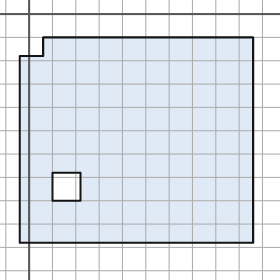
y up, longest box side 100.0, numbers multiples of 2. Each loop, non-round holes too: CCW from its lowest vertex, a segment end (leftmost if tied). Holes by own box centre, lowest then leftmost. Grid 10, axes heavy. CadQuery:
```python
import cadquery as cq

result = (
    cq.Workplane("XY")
    .moveTo(-4.0, -98.0)
    .lineTo(96.0, -98.0)
    .lineTo(96.0, -10.0)
    .lineTo(6.0, -10.0)
    .lineTo(6.0, -18.0)
    .lineTo(-4.0, -18.0)
    .close()
    .moveTo(10.0, -80.0)
    .lineTo(22.0, -80.0)
    .lineTo(22.0, -68.0)
    .lineTo(10.0, -68.0)
    .close()
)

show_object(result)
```